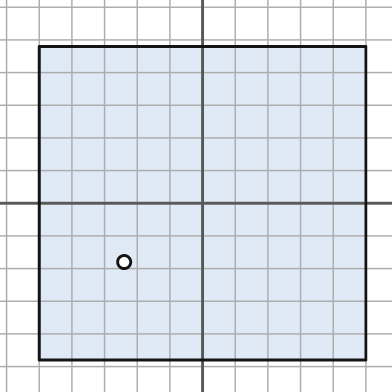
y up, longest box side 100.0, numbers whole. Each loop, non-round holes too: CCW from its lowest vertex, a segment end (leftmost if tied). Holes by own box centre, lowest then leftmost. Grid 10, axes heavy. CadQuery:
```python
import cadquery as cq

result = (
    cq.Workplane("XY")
    .moveTo(-50.0, -48.0)
    .lineTo(50.0, -48.0)
    .lineTo(50.0, 48.0)
    .lineTo(-50.0, 48.0)
    .close()
    .moveTo(-24.0, -18.0)
    .circle(2.0)
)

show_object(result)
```